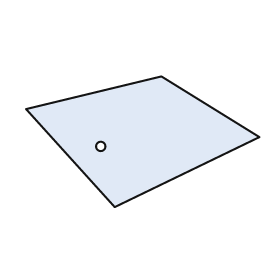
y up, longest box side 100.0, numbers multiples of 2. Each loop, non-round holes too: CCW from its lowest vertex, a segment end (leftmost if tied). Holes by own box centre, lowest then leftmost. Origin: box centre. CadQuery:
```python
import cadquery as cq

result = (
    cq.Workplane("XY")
    .moveTo(-12.0, -28.0)
    .lineTo(50.0, 2.0)
    .lineTo(8.0, 28.0)
    .lineTo(-50.0, 14.0)
    .close()
    .moveTo(-18.0, -2.0)
    .circle(2.0)
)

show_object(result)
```